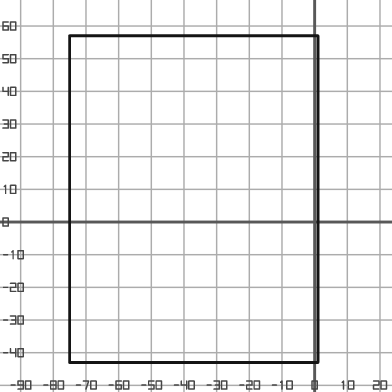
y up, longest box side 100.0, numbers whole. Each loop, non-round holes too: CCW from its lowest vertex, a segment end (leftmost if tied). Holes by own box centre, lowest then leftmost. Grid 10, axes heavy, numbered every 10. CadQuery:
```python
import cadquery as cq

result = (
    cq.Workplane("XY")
    .moveTo(-75.0, -43.0)
    .lineTo(1.0, -43.0)
    .lineTo(1.0, 57.0)
    .lineTo(-75.0, 57.0)
    .close()
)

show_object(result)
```